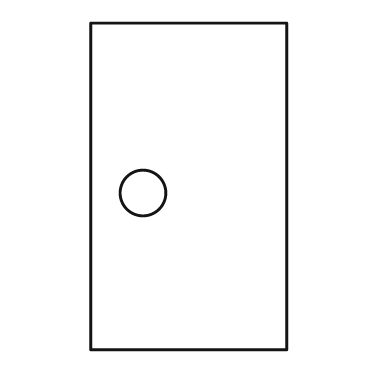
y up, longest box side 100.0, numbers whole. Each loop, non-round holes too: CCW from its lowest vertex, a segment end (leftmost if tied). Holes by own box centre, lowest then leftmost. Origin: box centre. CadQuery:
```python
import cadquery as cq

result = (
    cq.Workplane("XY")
    .moveTo(-30.0, -50.0)
    .lineTo(30.0, -50.0)
    .lineTo(30.0, 50.0)
    .lineTo(-30.0, 50.0)
    .close()
    .moveTo(-14.0, -2.0)
    .circle(7.0)
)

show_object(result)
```